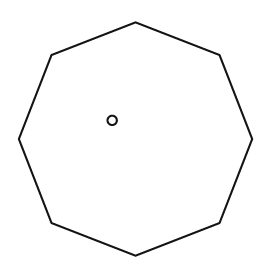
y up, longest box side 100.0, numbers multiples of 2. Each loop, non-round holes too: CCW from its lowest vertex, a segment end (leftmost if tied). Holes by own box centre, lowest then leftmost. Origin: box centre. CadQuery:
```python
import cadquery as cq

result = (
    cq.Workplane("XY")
    .moveTo(0.0, -50.0)
    .lineTo(36.0, -36.0)
    .lineTo(50.0, 0.0)
    .lineTo(36.0, 36.0)
    .lineTo(0.0, 50.0)
    .lineTo(-36.0, 36.0)
    .lineTo(-50.0, 0.0)
    .lineTo(-36.0, -36.0)
    .close()
    .moveTo(-10.0, 8.0)
    .circle(2.0)
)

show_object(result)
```